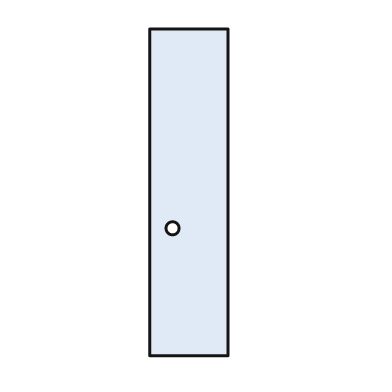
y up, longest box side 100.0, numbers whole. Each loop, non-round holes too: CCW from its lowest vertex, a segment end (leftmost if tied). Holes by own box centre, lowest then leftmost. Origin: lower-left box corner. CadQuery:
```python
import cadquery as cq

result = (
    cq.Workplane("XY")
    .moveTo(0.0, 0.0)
    .lineTo(24.0, 0.0)
    .lineTo(24.0, 100.0)
    .lineTo(0.0, 100.0)
    .close()
    .moveTo(7.0, 39.0)
    .circle(2.0)
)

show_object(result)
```